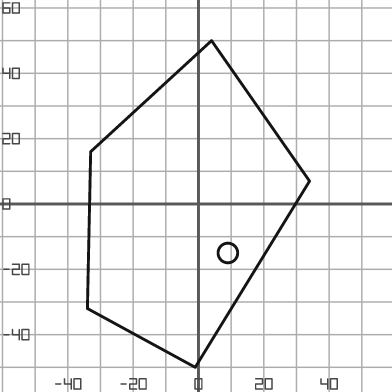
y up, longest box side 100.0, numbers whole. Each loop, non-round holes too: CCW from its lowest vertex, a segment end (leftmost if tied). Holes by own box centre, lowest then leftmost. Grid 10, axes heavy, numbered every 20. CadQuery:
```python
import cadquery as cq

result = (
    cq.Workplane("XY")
    .moveTo(-1.0, -50.0)
    .lineTo(34.0, 7.0)
    .lineTo(4.0, 50.0)
    .lineTo(-33.0, 16.0)
    .lineTo(-34.0, -32.0)
    .close()
    .moveTo(9.0, -15.0)
    .circle(3.0)
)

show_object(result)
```